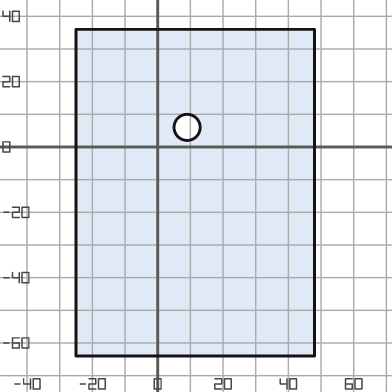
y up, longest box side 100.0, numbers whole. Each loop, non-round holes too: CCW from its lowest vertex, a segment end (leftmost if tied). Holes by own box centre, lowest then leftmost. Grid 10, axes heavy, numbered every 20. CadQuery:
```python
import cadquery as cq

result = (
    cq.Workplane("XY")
    .moveTo(-25.0, -64.0)
    .lineTo(48.0, -64.0)
    .lineTo(48.0, 36.0)
    .lineTo(-25.0, 36.0)
    .close()
    .moveTo(9.0, 6.0)
    .circle(4.0)
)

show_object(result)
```